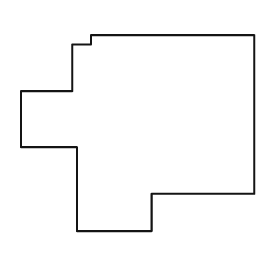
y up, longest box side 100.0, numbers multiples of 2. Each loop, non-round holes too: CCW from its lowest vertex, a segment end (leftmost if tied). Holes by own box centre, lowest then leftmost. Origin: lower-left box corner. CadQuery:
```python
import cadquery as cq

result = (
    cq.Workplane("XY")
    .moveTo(24.0, 0.0)
    .lineTo(56.0, 0.0)
    .lineTo(56.0, 16.0)
    .lineTo(100.0, 16.0)
    .lineTo(100.0, 84.0)
    .lineTo(30.0, 84.0)
    .lineTo(30.0, 80.0)
    .lineTo(22.0, 80.0)
    .lineTo(22.0, 60.0)
    .lineTo(0.0, 60.0)
    .lineTo(0.0, 36.0)
    .lineTo(24.0, 36.0)
    .close()
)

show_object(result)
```